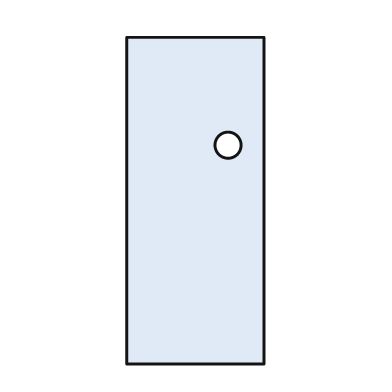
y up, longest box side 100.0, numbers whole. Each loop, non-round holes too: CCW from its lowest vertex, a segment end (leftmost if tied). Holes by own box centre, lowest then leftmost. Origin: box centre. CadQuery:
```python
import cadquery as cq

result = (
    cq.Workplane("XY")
    .moveTo(-21.0, -50.0)
    .lineTo(21.0, -50.0)
    .lineTo(21.0, 50.0)
    .lineTo(-21.0, 50.0)
    .close()
    .moveTo(10.0, 17.0)
    .circle(4.0)
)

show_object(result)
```